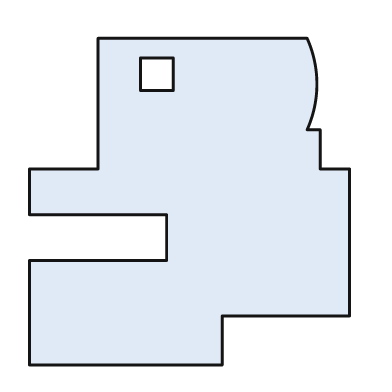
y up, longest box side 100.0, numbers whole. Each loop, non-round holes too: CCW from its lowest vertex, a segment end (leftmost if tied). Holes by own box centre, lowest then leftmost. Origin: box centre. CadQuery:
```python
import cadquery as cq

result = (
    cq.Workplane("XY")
    .moveTo(-49.0, -50.0)
    .lineTo(10.0, -50.0)
    .lineTo(10.0, -35.0)
    .lineTo(49.0, -35.0)
    .lineTo(49.0, 10.0)
    .lineTo(40.0, 10.0)
    .lineTo(40.0, 22.0)
    .lineTo(36.0, 22.0)
    .threePointArc((39.0, 36.0), (36.0, 50.0))
    .lineTo(-28.0, 50.0)
    .lineTo(-28.0, 10.0)
    .lineTo(-49.0, 10.0)
    .lineTo(-49.0, -4.0)
    .lineTo(-7.0, -4.0)
    .lineTo(-7.0, -18.0)
    .lineTo(-49.0, -18.0)
    .close()
    .moveTo(-15.0, 34.0)
    .lineTo(-5.0, 34.0)
    .lineTo(-5.0, 44.0)
    .lineTo(-15.0, 44.0)
    .close()
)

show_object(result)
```